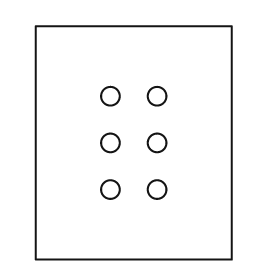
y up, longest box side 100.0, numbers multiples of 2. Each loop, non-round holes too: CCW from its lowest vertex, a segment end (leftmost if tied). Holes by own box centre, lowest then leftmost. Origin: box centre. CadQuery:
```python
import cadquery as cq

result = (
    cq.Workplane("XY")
    .moveTo(-42.0, -50.0)
    .lineTo(42.0, -50.0)
    .lineTo(42.0, 50.0)
    .lineTo(-42.0, 50.0)
    .close()
    .moveTo(-10.0, -20.0)
    .circle(4.0)
    .moveTo(10.0, -20.0)
    .circle(4.0)
    .moveTo(-10.0, 0.0)
    .circle(4.0)
    .moveTo(10.0, 0.0)
    .circle(4.0)
    .moveTo(-10.0, 20.0)
    .circle(4.0)
    .moveTo(10.0, 20.0)
    .circle(4.0)
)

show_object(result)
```